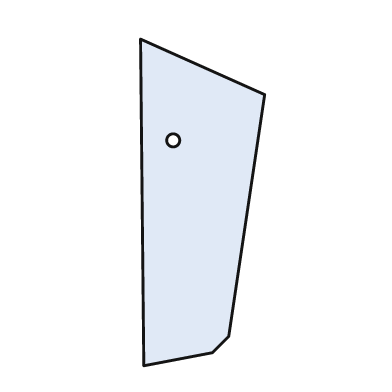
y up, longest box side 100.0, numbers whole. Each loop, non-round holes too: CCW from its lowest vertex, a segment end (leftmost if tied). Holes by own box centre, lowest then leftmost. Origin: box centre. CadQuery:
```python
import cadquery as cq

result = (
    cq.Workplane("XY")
    .moveTo(-18.0, -50.0)
    .lineTo(3.0, -46.0)
    .lineTo(8.0, -41.0)
    .lineTo(19.0, 33.0)
    .lineTo(-19.0, 50.0)
    .close()
    .moveTo(-9.0, 19.0)
    .circle(2.0)
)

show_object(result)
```